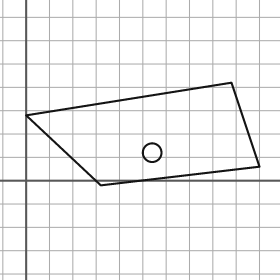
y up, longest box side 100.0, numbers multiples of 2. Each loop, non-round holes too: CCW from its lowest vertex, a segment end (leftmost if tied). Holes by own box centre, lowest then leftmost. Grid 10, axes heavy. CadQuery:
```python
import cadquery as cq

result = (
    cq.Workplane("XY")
    .moveTo(32.0, -2.0)
    .lineTo(100.0, 6.0)
    .lineTo(88.0, 42.0)
    .lineTo(0.0, 28.0)
    .close()
    .moveTo(54.0, 12.0)
    .circle(4.0)
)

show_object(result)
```